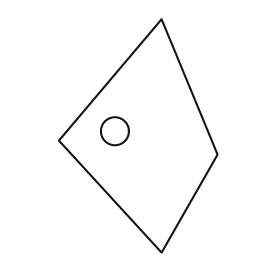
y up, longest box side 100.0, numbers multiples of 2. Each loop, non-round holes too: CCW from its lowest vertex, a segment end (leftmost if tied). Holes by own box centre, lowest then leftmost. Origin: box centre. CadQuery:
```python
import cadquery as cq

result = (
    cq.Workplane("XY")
    .moveTo(10.0, -50.0)
    .lineTo(34.0, -8.0)
    .lineTo(10.0, 50.0)
    .lineTo(-34.0, -2.0)
    .close()
    .moveTo(-10.0, 2.0)
    .circle(6.0)
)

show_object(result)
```